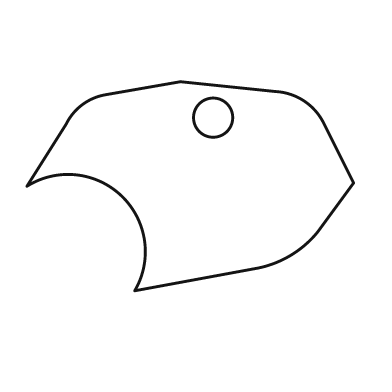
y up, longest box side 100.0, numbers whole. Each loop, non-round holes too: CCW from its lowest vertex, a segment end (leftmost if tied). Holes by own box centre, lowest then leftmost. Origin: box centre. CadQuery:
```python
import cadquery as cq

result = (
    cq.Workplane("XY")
    .moveTo(-17.0, -32.0)
    .lineTo(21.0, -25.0)
    .threePointArc((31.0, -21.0), (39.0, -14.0))
    .lineTo(50.0, 1.0)
    .lineTo(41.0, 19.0)
    .threePointArc((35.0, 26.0), (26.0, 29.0))
    .lineTo(-3.0, 32.0)
    .lineTo(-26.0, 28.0)
    .threePointArc((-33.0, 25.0), (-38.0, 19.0))
    .lineTo(-50.0, 0.0)
    .threePointArc((-21.0, -3.0), (-17.0, -32.0))
    .close()
    .moveTo(7.0, 21.0)
    .circle(6.0)
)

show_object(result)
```